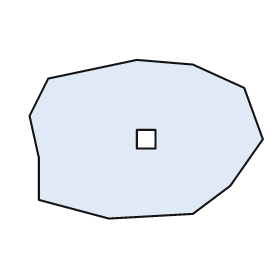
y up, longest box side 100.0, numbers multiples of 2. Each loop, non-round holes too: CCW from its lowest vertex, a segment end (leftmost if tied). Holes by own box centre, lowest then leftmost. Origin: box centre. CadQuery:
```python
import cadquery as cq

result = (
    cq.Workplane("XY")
    .moveTo(-16.0, -34.0)
    .lineTo(20.0, -32.0)
    .lineTo(36.0, -20.0)
    .lineTo(50.0, 0.0)
    .lineTo(42.0, 22.0)
    .lineTo(20.0, 32.0)
    .lineTo(-4.0, 34.0)
    .lineTo(-42.0, 26.0)
    .lineTo(-50.0, 10.0)
    .lineTo(-46.0, -8.0)
    .lineTo(-46.0, -26.0)
    .close()
    .moveTo(-4.0, -4.0)
    .lineTo(4.0, -4.0)
    .lineTo(4.0, 4.0)
    .lineTo(-4.0, 4.0)
    .close()
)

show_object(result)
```